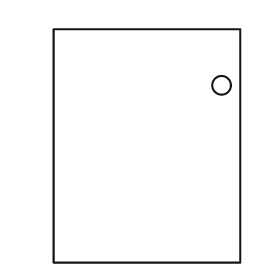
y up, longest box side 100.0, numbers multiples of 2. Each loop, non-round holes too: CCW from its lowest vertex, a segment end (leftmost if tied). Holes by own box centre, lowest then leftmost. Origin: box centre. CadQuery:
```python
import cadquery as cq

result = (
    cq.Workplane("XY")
    .moveTo(-40.0, -50.0)
    .lineTo(40.0, -50.0)
    .lineTo(40.0, 50.0)
    .lineTo(-40.0, 50.0)
    .close()
    .moveTo(32.0, 26.0)
    .circle(4.0)
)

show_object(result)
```